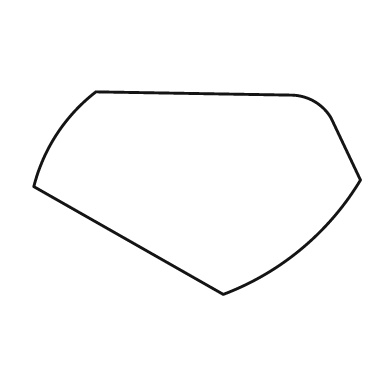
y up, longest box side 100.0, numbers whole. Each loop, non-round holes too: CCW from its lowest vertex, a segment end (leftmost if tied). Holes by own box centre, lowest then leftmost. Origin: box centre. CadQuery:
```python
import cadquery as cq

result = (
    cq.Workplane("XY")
    .moveTo(8.0, -31.0)
    .threePointArc((32.0, -17.0), (50.0, 4.0))
    .lineTo(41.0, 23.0)
    .threePointArc((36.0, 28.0), (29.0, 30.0))
    .lineTo(-31.0, 31.0)
    .threePointArc((-43.0, 18.0), (-50.0, 2.0))
    .close()
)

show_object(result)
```